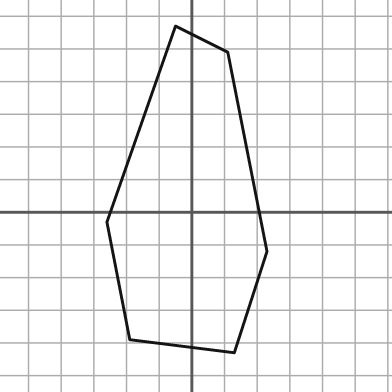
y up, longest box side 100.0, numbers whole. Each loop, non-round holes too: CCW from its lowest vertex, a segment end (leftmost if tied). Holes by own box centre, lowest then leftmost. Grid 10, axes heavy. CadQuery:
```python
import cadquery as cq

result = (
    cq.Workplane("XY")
    .moveTo(13.0, -43.0)
    .lineTo(23.0, -12.0)
    .lineTo(11.0, 49.0)
    .lineTo(-5.0, 57.0)
    .lineTo(-26.0, -3.0)
    .lineTo(-19.0, -39.0)
    .close()
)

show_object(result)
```